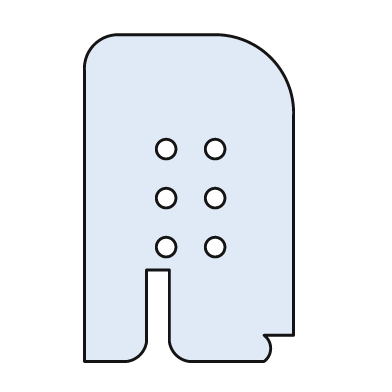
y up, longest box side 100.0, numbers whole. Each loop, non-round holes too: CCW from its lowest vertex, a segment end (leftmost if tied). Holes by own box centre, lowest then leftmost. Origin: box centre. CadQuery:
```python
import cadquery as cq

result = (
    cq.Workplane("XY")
    .moveTo(-32.0, -50.0)
    .lineTo(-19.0, -50.0)
    .threePointArc((-15.0, -48.0), (-13.0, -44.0))
    .lineTo(-13.0, -22.0)
    .lineTo(-6.0, -22.0)
    .lineTo(-6.0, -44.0)
    .threePointArc((-4.0, -48.0), (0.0, -50.0))
    .lineTo(23.0, -50.0)
    .threePointArc((25.0, -46.0), (23.0, -42.0))
    .lineTo(32.0, -42.0)
    .lineTo(32.0, 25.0)
    .threePointArc((25.0, 43.0), (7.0, 50.0))
    .lineTo(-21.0, 50.0)
    .threePointArc((-29.0, 47.0), (-32.0, 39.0))
    .close()
    .moveTo(-7.0, -15.0)
    .circle(3.0)
    .moveTo(8.0, -15.0)
    .circle(3.0)
    .moveTo(-7.0, 0.0)
    .circle(3.0)
    .moveTo(8.0, 0.0)
    .circle(3.0)
    .moveTo(-7.0, 15.0)
    .circle(3.0)
    .moveTo(8.0, 15.0)
    .circle(3.0)
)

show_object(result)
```